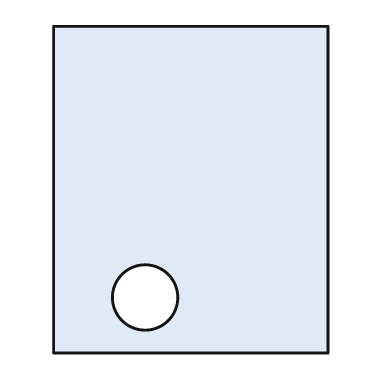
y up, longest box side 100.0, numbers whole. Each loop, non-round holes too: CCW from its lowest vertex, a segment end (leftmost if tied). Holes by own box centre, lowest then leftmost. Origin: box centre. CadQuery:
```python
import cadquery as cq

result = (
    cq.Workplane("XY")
    .moveTo(-42.0, -50.0)
    .lineTo(42.0, -50.0)
    .lineTo(42.0, 50.0)
    .lineTo(-42.0, 50.0)
    .close()
    .moveTo(-14.0, -33.0)
    .circle(10.0)
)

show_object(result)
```